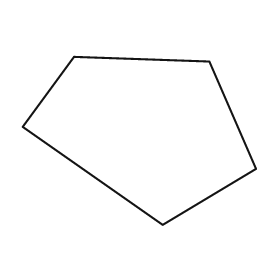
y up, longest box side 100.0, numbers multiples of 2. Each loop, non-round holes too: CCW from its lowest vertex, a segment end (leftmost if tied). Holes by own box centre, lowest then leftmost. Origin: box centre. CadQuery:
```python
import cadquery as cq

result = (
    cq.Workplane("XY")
    .moveTo(10.0, -36.0)
    .lineTo(50.0, -12.0)
    .lineTo(30.0, 34.0)
    .lineTo(-28.0, 36.0)
    .lineTo(-50.0, 6.0)
    .close()
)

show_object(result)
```